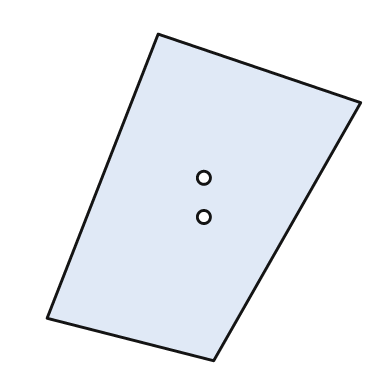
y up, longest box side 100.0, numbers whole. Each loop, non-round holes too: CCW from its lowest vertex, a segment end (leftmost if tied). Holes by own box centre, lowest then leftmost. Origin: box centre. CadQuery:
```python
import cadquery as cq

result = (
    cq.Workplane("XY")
    .moveTo(3.0, -50.0)
    .lineTo(48.0, 29.0)
    .lineTo(-14.0, 50.0)
    .lineTo(-48.0, -37.0)
    .close()
    .moveTo(0.0, -6.0)
    .circle(2.0)
    .moveTo(0.0, 6.0)
    .circle(2.0)
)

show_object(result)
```